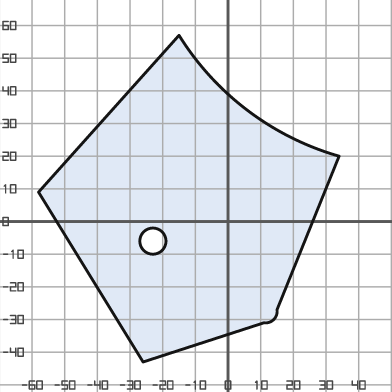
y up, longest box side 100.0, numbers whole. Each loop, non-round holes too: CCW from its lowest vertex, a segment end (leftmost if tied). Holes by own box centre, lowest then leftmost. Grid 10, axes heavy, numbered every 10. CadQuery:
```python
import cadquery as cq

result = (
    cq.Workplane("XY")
    .moveTo(-26.0, -43.0)
    .lineTo(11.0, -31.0)
    .threePointArc((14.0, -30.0), (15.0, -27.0))
    .lineTo(34.0, 20.0)
    .threePointArc((6.0, 34.0), (-15.0, 57.0))
    .lineTo(-58.0, 9.0)
    .close()
    .moveTo(-23.0, -6.0)
    .circle(4.0)
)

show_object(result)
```